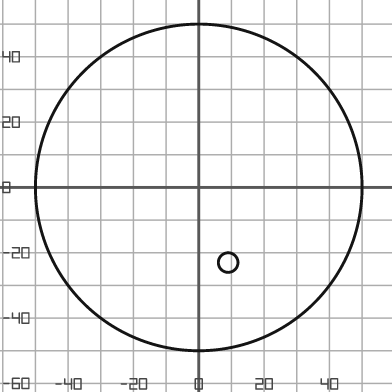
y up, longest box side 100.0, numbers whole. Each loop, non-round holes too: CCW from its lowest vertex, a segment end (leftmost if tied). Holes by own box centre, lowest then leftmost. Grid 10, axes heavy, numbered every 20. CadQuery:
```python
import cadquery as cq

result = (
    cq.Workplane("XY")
    .moveTo(0.0, 0.0)
    .circle(50.0)
    .moveTo(9.0, -23.0)
    .circle(3.0)
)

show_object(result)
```